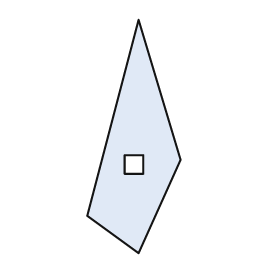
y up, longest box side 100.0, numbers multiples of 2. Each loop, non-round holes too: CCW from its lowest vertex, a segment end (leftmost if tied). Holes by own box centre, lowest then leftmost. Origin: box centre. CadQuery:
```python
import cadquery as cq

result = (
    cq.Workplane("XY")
    .moveTo(2.0, -50.0)
    .lineTo(20.0, -10.0)
    .lineTo(2.0, 50.0)
    .lineTo(-20.0, -34.0)
    .close()
    .moveTo(-4.0, -16.0)
    .lineTo(4.0, -16.0)
    .lineTo(4.0, -8.0)
    .lineTo(-4.0, -8.0)
    .close()
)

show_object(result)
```